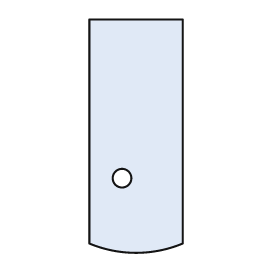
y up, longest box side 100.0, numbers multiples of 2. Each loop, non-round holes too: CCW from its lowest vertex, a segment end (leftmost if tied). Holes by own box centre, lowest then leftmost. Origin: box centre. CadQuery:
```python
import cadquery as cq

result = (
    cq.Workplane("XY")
    .moveTo(-20.0, -46.0)
    .threePointArc((0.0, -50.0), (20.0, -46.0))
    .lineTo(20.0, 50.0)
    .lineTo(-20.0, 50.0)
    .close()
    .moveTo(-6.0, -18.0)
    .circle(4.0)
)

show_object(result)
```